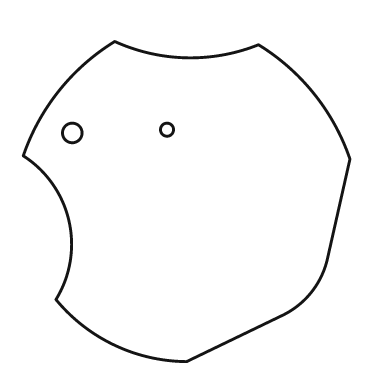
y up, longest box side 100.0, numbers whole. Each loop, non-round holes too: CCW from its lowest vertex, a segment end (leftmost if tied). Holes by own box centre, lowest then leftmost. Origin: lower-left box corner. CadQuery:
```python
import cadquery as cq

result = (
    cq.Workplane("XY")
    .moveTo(50.0, 0.0)
    .lineTo(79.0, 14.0)
    .threePointArc((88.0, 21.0), (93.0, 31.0))
    .lineTo(100.0, 62.0)
    .threePointArc((89.0, 82.0), (72.0, 97.0))
    .threePointArc((50.0, 93.0), (28.0, 98.0))
    .threePointArc((11.0, 83.0), (0.0, 63.0))
    .threePointArc((14.0, 43.0), (10.0, 19.0))
    .threePointArc((28.0, 5.0), (50.0, 0.0))
    .close()
    .moveTo(15.0, 70.0)
    .circle(3.0)
    .moveTo(44.0, 71.0)
    .circle(2.0)
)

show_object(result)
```